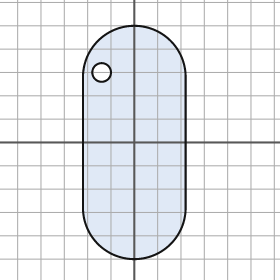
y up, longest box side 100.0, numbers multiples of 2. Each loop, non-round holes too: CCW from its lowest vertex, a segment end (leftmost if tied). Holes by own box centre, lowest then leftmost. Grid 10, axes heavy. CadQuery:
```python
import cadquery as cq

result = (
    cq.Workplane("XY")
    .moveTo(-22.0, -28.0)
    .threePointArc((0.0, -50.0), (22.0, -28.0))
    .lineTo(22.0, 28.0)
    .threePointArc((0.0, 50.0), (-22.0, 28.0))
    .close()
    .moveTo(-14.0, 30.0)
    .circle(4.0)
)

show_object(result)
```